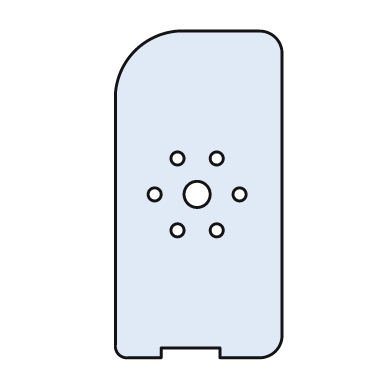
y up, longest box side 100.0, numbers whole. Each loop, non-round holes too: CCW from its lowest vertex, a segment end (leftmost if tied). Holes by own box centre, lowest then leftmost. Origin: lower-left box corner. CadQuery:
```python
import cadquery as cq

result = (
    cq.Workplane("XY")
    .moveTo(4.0, 0.0)
    .lineTo(14.0, 0.0)
    .lineTo(14.0, 3.0)
    .lineTo(32.0, 3.0)
    .lineTo(32.0, 0.0)
    .lineTo(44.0, 0.0)
    .threePointArc((49.0, 2.0), (51.0, 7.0))
    .lineTo(51.0, 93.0)
    .threePointArc((49.0, 98.0), (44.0, 100.0))
    .lineTo(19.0, 100.0)
    .threePointArc((6.0, 94.0), (0.0, 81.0))
    .lineTo(0.0, 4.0)
    .threePointArc((1.0, 1.0), (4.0, 0.0))
    .close()
    .moveTo(19.0, 39.0)
    .circle(2.0)
    .moveTo(31.0, 39.0)
    .circle(2.0)
    .moveTo(12.0, 50.0)
    .circle(2.0)
    .moveTo(25.0, 50.0)
    .circle(4.0)
    .moveTo(38.0, 50.0)
    .circle(2.0)
    .moveTo(19.0, 61.0)
    .circle(2.0)
    .moveTo(31.0, 61.0)
    .circle(2.0)
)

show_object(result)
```